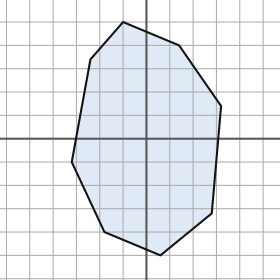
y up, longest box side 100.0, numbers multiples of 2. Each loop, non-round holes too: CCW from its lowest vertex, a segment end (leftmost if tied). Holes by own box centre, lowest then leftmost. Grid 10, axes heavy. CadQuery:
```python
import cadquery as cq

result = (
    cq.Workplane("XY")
    .moveTo(6.0, -50.0)
    .lineTo(28.0, -32.0)
    .lineTo(32.0, 14.0)
    .lineTo(14.0, 40.0)
    .lineTo(-10.0, 50.0)
    .lineTo(-24.0, 34.0)
    .lineTo(-32.0, -10.0)
    .lineTo(-18.0, -40.0)
    .close()
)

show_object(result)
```